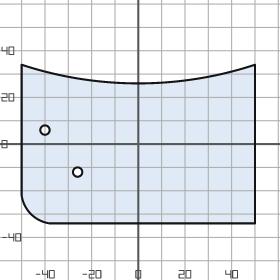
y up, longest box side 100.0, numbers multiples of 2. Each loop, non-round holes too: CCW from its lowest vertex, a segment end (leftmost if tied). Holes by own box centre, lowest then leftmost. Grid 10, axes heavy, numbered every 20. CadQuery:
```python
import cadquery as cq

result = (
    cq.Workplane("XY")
    .moveTo(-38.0, -34.0)
    .lineTo(50.0, -34.0)
    .lineTo(50.0, 34.0)
    .threePointArc((0.0, 26.0), (-50.0, 34.0))
    .lineTo(-50.0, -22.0)
    .threePointArc((-46.0, -30.0), (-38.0, -34.0))
    .close()
    .moveTo(-26.0, -12.0)
    .circle(2.0)
    .moveTo(-40.0, 6.0)
    .circle(2.0)
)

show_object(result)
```